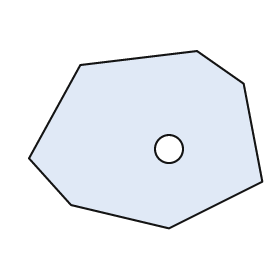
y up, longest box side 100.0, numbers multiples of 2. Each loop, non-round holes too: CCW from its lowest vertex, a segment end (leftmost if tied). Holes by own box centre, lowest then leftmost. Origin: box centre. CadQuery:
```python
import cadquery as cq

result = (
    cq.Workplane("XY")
    .moveTo(10.0, -38.0)
    .lineTo(50.0, -18.0)
    .lineTo(42.0, 24.0)
    .lineTo(22.0, 38.0)
    .lineTo(-28.0, 32.0)
    .lineTo(-50.0, -8.0)
    .lineTo(-32.0, -28.0)
    .close()
    .moveTo(10.0, -4.0)
    .circle(6.0)
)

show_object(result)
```